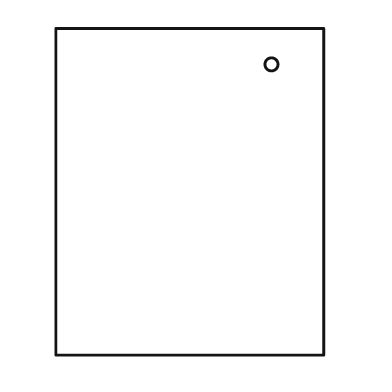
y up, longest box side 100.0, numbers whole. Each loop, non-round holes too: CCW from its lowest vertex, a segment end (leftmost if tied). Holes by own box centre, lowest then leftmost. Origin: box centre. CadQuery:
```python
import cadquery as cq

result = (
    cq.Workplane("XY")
    .moveTo(-41.0, -50.0)
    .lineTo(41.0, -50.0)
    .lineTo(41.0, 50.0)
    .lineTo(-41.0, 50.0)
    .close()
    .moveTo(25.0, 39.0)
    .circle(2.0)
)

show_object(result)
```